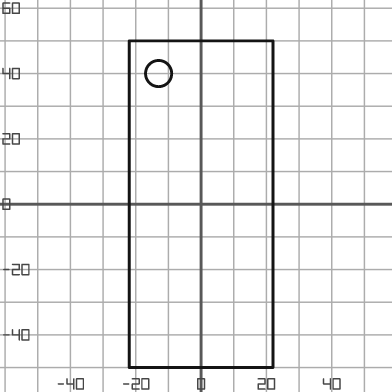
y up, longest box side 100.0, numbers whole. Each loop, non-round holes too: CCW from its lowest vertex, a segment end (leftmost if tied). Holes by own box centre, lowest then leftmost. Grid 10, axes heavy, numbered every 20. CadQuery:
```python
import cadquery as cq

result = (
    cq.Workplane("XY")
    .moveTo(-22.0, -50.0)
    .lineTo(22.0, -50.0)
    .lineTo(22.0, 50.0)
    .lineTo(-22.0, 50.0)
    .close()
    .moveTo(-13.0, 40.0)
    .circle(4.0)
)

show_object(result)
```